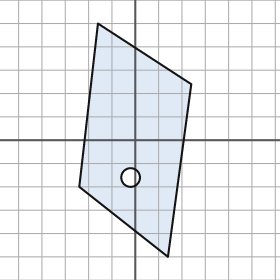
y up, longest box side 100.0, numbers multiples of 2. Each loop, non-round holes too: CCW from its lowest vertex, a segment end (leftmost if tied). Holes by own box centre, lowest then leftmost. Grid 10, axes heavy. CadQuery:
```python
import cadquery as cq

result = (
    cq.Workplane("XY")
    .moveTo(14.0, -50.0)
    .lineTo(24.0, 24.0)
    .lineTo(-16.0, 50.0)
    .lineTo(-24.0, -20.0)
    .close()
    .moveTo(-2.0, -16.0)
    .circle(4.0)
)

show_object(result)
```